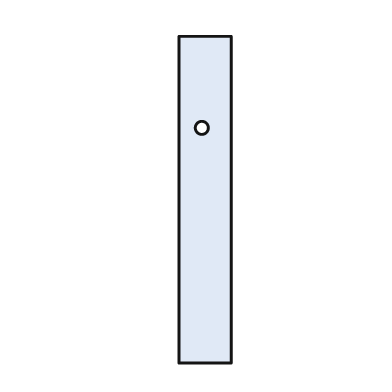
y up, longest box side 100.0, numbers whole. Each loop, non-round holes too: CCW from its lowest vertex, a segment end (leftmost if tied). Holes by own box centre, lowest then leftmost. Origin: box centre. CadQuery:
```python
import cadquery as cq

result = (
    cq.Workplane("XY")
    .moveTo(-8.0, -50.0)
    .lineTo(8.0, -50.0)
    .lineTo(8.0, 50.0)
    .lineTo(-8.0, 50.0)
    .close()
    .moveTo(-1.0, 22.0)
    .circle(2.0)
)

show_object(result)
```